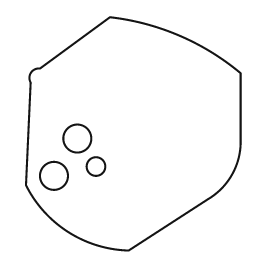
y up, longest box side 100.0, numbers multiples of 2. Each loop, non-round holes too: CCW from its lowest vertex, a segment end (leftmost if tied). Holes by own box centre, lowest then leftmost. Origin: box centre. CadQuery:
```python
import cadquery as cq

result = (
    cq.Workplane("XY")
    .moveTo(-2.0, -50.0)
    .lineTo(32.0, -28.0)
    .threePointArc((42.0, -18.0), (46.0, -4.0))
    .lineTo(46.0, 26.0)
    .threePointArc((20.0, 42.0), (-10.0, 50.0))
    .lineTo(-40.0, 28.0)
    .threePointArc((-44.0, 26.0), (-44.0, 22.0))
    .lineTo(-46.0, -22.0)
    .threePointArc((-28.0, -42.0), (-2.0, -50.0))
    .close()
    .moveTo(-34.0, -18.0)
    .circle(6.0)
    .moveTo(-16.0, -14.0)
    .circle(4.0)
    .moveTo(-24.0, -2.0)
    .circle(6.0)
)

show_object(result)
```